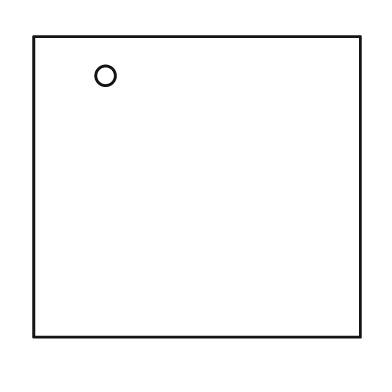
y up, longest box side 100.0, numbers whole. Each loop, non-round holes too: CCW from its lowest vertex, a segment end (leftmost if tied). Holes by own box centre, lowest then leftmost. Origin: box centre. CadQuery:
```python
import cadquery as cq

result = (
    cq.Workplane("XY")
    .moveTo(-50.0, -46.0)
    .lineTo(50.0, -46.0)
    .lineTo(50.0, 46.0)
    .lineTo(-50.0, 46.0)
    .close()
    .moveTo(-28.0, 34.0)
    .circle(3.0)
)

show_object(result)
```